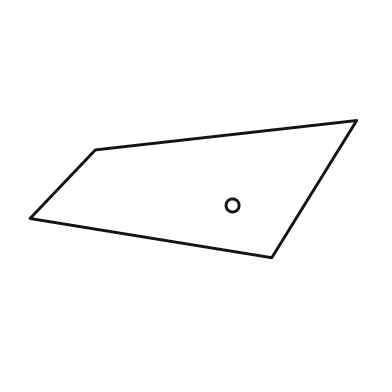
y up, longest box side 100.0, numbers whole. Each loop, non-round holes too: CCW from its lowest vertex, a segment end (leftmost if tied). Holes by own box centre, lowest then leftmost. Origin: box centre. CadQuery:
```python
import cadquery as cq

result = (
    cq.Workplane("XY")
    .moveTo(24.0, -21.0)
    .lineTo(50.0, 21.0)
    .lineTo(-30.0, 12.0)
    .lineTo(-50.0, -9.0)
    .close()
    .moveTo(12.0, -5.0)
    .circle(2.0)
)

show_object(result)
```